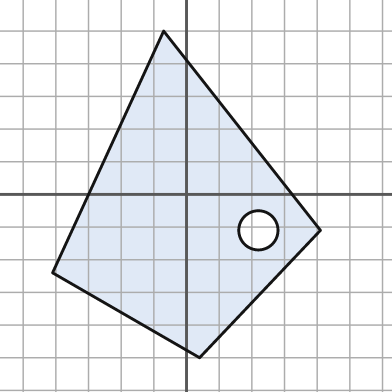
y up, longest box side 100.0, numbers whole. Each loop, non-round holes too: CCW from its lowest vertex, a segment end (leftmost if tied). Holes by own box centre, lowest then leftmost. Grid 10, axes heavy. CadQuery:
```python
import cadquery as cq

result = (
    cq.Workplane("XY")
    .moveTo(4.0, -50.0)
    .lineTo(41.0, -11.0)
    .lineTo(-7.0, 50.0)
    .lineTo(-41.0, -24.0)
    .close()
    .moveTo(22.0, -11.0)
    .circle(6.0)
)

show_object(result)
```